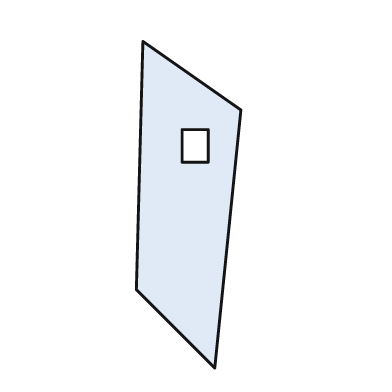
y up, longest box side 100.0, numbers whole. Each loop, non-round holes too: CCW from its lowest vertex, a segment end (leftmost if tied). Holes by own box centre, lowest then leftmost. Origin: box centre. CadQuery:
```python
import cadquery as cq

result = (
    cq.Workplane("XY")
    .moveTo(8.0, -50.0)
    .lineTo(16.0, 29.0)
    .lineTo(-14.0, 50.0)
    .lineTo(-16.0, -26.0)
    .close()
    .moveTo(-2.0, 13.0)
    .lineTo(6.0, 13.0)
    .lineTo(6.0, 23.0)
    .lineTo(-2.0, 23.0)
    .close()
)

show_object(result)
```